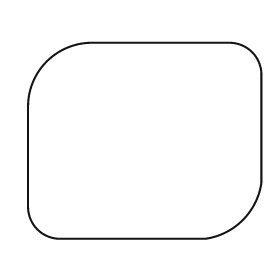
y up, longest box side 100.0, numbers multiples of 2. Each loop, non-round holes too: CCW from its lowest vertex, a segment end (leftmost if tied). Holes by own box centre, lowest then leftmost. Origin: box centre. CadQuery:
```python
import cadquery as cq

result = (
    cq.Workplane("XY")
    .moveTo(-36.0, -42.0)
    .lineTo(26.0, -42.0)
    .threePointArc((42.0, -34.0), (50.0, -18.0))
    .lineTo(50.0, 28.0)
    .threePointArc((46.0, 38.0), (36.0, 42.0))
    .lineTo(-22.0, 42.0)
    .threePointArc((-42.0, 34.0), (-50.0, 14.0))
    .lineTo(-50.0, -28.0)
    .threePointArc((-46.0, -38.0), (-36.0, -42.0))
    .close()
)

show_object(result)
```